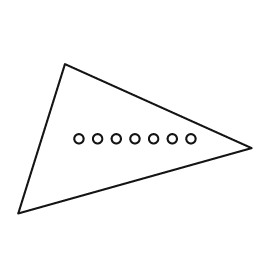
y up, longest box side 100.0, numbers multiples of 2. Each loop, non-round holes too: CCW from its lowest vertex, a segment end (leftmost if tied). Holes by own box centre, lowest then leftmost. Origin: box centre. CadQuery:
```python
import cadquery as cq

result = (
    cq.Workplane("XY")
    .moveTo(-50.0, -32.0)
    .lineTo(50.0, -4.0)
    .lineTo(-30.0, 32.0)
    .close()
    .moveTo(-24.0, 0.0)
    .circle(2.0)
    .moveTo(-16.0, 0.0)
    .circle(2.0)
    .moveTo(-8.0, 0.0)
    .circle(2.0)
    .moveTo(0.0, 0.0)
    .circle(2.0)
    .moveTo(8.0, 0.0)
    .circle(2.0)
    .moveTo(16.0, 0.0)
    .circle(2.0)
    .moveTo(24.0, 0.0)
    .circle(2.0)
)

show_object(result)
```